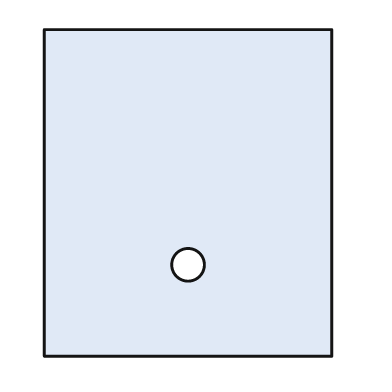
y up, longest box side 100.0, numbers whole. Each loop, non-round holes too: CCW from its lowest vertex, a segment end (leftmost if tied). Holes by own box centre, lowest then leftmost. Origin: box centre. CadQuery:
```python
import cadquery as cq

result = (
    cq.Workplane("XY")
    .moveTo(-44.0, -50.0)
    .lineTo(44.0, -50.0)
    .lineTo(44.0, 50.0)
    .lineTo(-44.0, 50.0)
    .close()
    .moveTo(0.0, -22.0)
    .circle(5.0)
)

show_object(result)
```